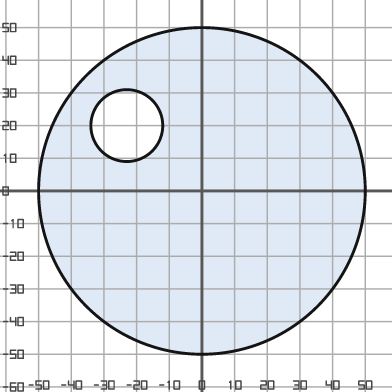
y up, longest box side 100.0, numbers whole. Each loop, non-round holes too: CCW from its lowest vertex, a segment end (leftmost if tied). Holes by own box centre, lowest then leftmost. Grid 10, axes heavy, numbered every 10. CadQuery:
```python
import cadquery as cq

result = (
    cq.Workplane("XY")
    .moveTo(0.0, 0.0)
    .circle(50.0)
    .moveTo(-23.0, 20.0)
    .circle(11.0)
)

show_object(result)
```